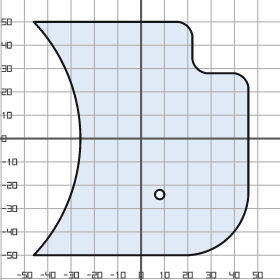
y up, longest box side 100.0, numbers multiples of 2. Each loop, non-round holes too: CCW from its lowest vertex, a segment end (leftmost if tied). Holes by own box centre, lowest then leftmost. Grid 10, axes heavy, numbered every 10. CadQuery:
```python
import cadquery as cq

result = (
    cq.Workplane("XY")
    .moveTo(-46.0, -50.0)
    .lineTo(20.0, -50.0)
    .threePointArc((38.0, -42.0), (46.0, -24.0))
    .lineTo(46.0, 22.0)
    .threePointArc((44.0, 26.0), (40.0, 28.0))
    .lineTo(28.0, 28.0)
    .threePointArc((24.0, 30.0), (22.0, 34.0))
    .lineTo(22.0, 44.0)
    .threePointArc((20.0, 48.0), (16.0, 50.0))
    .lineTo(-46.0, 50.0)
    .threePointArc((-26.0, 0.0), (-46.0, -50.0))
    .close()
    .moveTo(8.0, -24.0)
    .circle(2.0)
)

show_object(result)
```